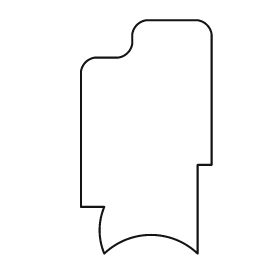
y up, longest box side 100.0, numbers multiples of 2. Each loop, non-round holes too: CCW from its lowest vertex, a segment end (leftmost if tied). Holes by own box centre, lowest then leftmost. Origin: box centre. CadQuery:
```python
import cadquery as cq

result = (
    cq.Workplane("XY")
    .moveTo(-18.0, -50.0)
    .threePointArc((2.0, -42.0), (22.0, -50.0))
    .lineTo(22.0, -12.0)
    .lineTo(28.0, -12.0)
    .lineTo(28.0, 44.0)
    .threePointArc((26.0, 48.0), (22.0, 50.0))
    .lineTo(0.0, 50.0)
    .threePointArc((-4.0, 48.0), (-6.0, 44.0))
    .lineTo(-6.0, 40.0)
    .threePointArc((-8.0, 36.0), (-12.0, 34.0))
    .lineTo(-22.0, 34.0)
    .threePointArc((-26.0, 32.0), (-28.0, 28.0))
    .lineTo(-28.0, -30.0)
    .lineTo(-18.0, -30.0)
    .threePointArc((-20.0, -40.0), (-18.0, -50.0))
    .close()
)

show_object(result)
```